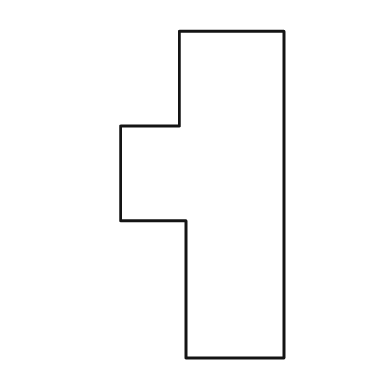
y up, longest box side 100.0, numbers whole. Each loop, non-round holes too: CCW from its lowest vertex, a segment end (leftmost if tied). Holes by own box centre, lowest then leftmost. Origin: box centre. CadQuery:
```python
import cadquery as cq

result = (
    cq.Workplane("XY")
    .moveTo(-5.0, -50.0)
    .lineTo(25.0, -50.0)
    .lineTo(25.0, 50.0)
    .lineTo(-7.0, 50.0)
    .lineTo(-7.0, 21.0)
    .lineTo(-25.0, 21.0)
    .lineTo(-25.0, -8.0)
    .lineTo(-5.0, -8.0)
    .close()
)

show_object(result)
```